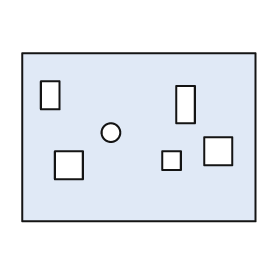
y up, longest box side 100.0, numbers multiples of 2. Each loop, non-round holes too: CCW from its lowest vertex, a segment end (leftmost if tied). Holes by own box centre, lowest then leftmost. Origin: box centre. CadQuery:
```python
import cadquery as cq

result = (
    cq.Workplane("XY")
    .moveTo(-50.0, -36.0)
    .lineTo(50.0, -36.0)
    .lineTo(50.0, 36.0)
    .lineTo(-50.0, 36.0)
    .close()
    .moveTo(-36.0, -18.0)
    .lineTo(-24.0, -18.0)
    .lineTo(-24.0, -6.0)
    .lineTo(-36.0, -6.0)
    .close()
    .moveTo(10.0, -14.0)
    .lineTo(18.0, -14.0)
    .lineTo(18.0, -6.0)
    .lineTo(10.0, -6.0)
    .close()
    .moveTo(28.0, -12.0)
    .lineTo(40.0, -12.0)
    .lineTo(40.0, 0.0)
    .lineTo(28.0, 0.0)
    .close()
    .moveTo(-12.0, 2.0)
    .circle(4.0)
    .moveTo(16.0, 6.0)
    .lineTo(24.0, 6.0)
    .lineTo(24.0, 22.0)
    .lineTo(16.0, 22.0)
    .close()
    .moveTo(-42.0, 12.0)
    .lineTo(-34.0, 12.0)
    .lineTo(-34.0, 24.0)
    .lineTo(-42.0, 24.0)
    .close()
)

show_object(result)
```